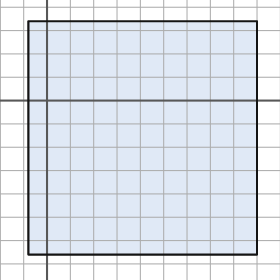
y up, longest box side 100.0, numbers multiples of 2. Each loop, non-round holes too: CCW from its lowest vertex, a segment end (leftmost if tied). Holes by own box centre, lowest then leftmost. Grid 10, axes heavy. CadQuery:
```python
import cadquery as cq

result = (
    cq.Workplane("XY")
    .moveTo(-8.0, -66.0)
    .lineTo(90.0, -66.0)
    .lineTo(90.0, 34.0)
    .lineTo(-8.0, 34.0)
    .close()
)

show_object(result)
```